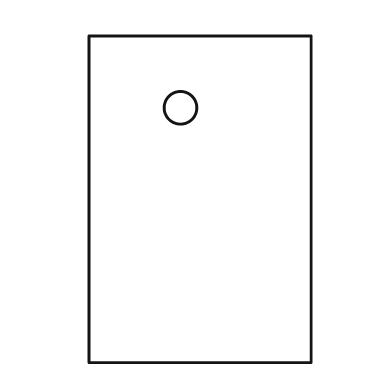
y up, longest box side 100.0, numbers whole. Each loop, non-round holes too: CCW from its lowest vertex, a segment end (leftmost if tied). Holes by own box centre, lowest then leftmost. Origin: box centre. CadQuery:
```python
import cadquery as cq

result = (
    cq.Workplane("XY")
    .moveTo(-34.0, -50.0)
    .lineTo(34.0, -50.0)
    .lineTo(34.0, 50.0)
    .lineTo(-34.0, 50.0)
    .close()
    .moveTo(-6.0, 28.0)
    .circle(5.0)
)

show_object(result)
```